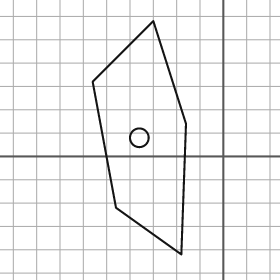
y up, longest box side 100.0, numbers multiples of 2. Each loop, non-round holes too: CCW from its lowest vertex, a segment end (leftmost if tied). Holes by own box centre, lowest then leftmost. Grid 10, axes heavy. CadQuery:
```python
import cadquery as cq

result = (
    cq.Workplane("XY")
    .moveTo(-18.0, -42.0)
    .lineTo(-16.0, 14.0)
    .lineTo(-30.0, 58.0)
    .lineTo(-56.0, 32.0)
    .lineTo(-46.0, -22.0)
    .close()
    .moveTo(-36.0, 8.0)
    .circle(4.0)
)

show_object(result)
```